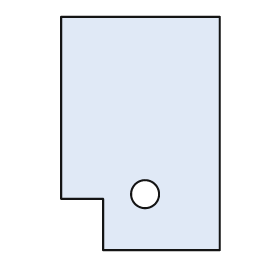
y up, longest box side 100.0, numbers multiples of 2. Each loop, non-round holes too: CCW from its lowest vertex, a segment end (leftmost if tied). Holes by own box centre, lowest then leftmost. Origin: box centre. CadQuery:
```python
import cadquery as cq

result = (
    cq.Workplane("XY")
    .moveTo(-16.0, -50.0)
    .lineTo(34.0, -50.0)
    .lineTo(34.0, 50.0)
    .lineTo(-34.0, 50.0)
    .lineTo(-34.0, -28.0)
    .lineTo(-16.0, -28.0)
    .close()
    .moveTo(2.0, -26.0)
    .circle(6.0)
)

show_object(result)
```